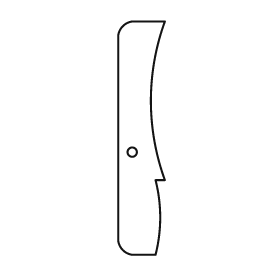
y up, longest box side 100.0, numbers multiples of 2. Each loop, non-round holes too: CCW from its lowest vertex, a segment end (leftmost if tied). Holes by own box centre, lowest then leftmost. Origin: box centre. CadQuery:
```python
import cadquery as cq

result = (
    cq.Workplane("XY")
    .moveTo(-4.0, -50.0)
    .lineTo(6.0, -50.0)
    .threePointArc((8.0, -34.0), (6.0, -18.0))
    .lineTo(10.0, -18.0)
    .threePointArc((4.0, 16.0), (10.0, 50.0))
    .lineTo(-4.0, 50.0)
    .threePointArc((-8.0, 48.0), (-10.0, 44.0))
    .lineTo(-10.0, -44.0)
    .threePointArc((-8.0, -48.0), (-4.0, -50.0))
    .close()
    .moveTo(-4.0, -6.0)
    .circle(2.0)
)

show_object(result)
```